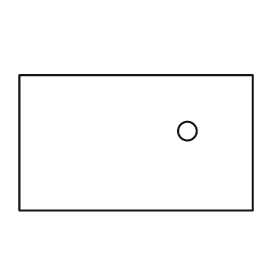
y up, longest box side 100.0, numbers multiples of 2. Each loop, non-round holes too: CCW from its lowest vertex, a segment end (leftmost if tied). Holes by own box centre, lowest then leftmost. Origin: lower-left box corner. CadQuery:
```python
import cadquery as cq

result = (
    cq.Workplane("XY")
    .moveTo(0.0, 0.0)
    .lineTo(100.0, 0.0)
    .lineTo(100.0, 58.0)
    .lineTo(0.0, 58.0)
    .close()
    .moveTo(72.0, 34.0)
    .circle(4.0)
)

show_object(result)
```